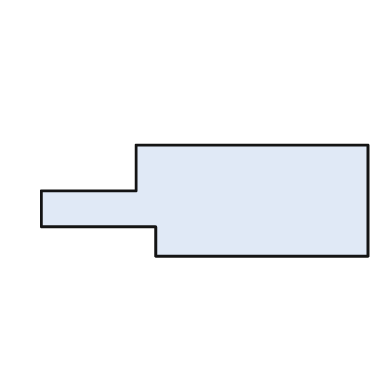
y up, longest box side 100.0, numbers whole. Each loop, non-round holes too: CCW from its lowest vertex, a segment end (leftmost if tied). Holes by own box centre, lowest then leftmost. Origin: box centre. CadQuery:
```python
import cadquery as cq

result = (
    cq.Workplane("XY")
    .moveTo(-15.0, -17.0)
    .lineTo(50.0, -17.0)
    .lineTo(50.0, 17.0)
    .lineTo(-21.0, 17.0)
    .lineTo(-21.0, 3.0)
    .lineTo(-50.0, 3.0)
    .lineTo(-50.0, -8.0)
    .lineTo(-15.0, -8.0)
    .close()
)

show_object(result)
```